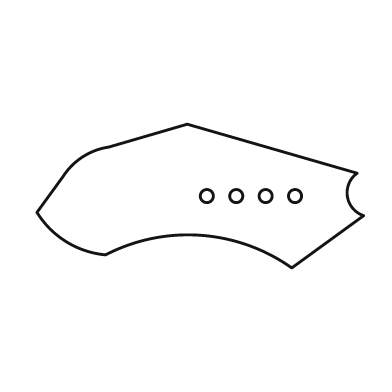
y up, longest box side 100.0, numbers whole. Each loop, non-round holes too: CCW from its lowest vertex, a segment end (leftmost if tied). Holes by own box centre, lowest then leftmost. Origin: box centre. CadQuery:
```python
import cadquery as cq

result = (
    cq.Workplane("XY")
    .moveTo(28.0, -22.0)
    .lineTo(50.0, -6.0)
    .threePointArc((45.0, 0.0), (48.0, 7.0))
    .lineTo(-4.0, 22.0)
    .lineTo(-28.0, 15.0)
    .threePointArc((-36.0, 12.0), (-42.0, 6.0))
    .lineTo(-50.0, -5.0)
    .threePointArc((-41.0, -14.0), (-29.0, -18.0))
    .threePointArc((0.0, -12.0), (28.0, -22.0))
    .close()
    .moveTo(2.0, 0.0)
    .circle(2.0)
    .moveTo(11.0, 0.0)
    .circle(2.0)
    .moveTo(20.0, 0.0)
    .circle(2.0)
    .moveTo(29.0, 0.0)
    .circle(2.0)
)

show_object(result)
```